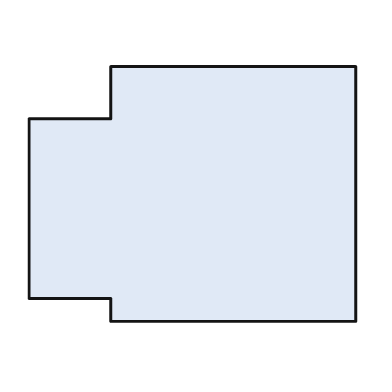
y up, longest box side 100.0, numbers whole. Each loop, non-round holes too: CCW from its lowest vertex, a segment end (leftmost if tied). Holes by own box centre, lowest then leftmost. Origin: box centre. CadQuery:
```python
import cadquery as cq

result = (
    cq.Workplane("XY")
    .moveTo(-25.0, -39.0)
    .lineTo(50.0, -39.0)
    .lineTo(50.0, 39.0)
    .lineTo(-25.0, 39.0)
    .lineTo(-25.0, 23.0)
    .lineTo(-50.0, 23.0)
    .lineTo(-50.0, -32.0)
    .lineTo(-25.0, -32.0)
    .close()
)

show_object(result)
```